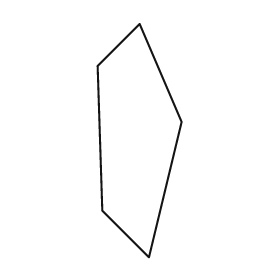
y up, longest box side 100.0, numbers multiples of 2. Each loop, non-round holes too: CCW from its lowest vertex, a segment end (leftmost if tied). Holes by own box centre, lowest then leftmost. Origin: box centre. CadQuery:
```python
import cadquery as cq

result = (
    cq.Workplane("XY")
    .moveTo(4.0, -50.0)
    .lineTo(18.0, 8.0)
    .lineTo(0.0, 50.0)
    .lineTo(-18.0, 32.0)
    .lineTo(-16.0, -30.0)
    .close()
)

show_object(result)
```